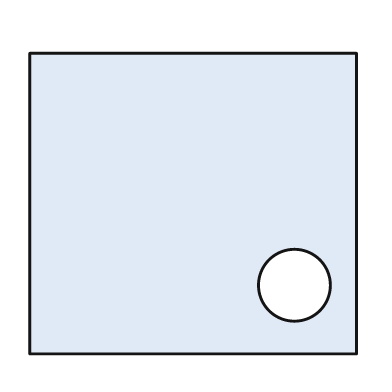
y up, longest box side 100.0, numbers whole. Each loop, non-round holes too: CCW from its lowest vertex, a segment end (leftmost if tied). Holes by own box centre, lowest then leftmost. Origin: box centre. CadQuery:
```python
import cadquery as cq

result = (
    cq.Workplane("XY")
    .moveTo(-50.0, -46.0)
    .lineTo(50.0, -46.0)
    .lineTo(50.0, 46.0)
    .lineTo(-50.0, 46.0)
    .close()
    .moveTo(31.0, -25.0)
    .circle(11.0)
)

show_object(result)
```